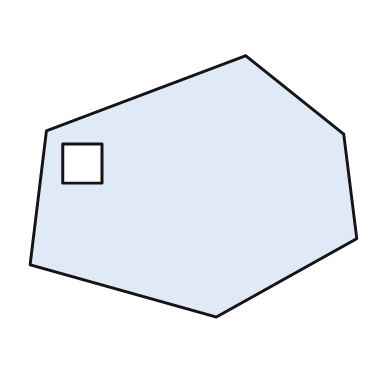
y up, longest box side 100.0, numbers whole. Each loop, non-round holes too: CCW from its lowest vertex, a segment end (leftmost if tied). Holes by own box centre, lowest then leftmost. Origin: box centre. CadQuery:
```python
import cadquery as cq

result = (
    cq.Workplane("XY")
    .moveTo(7.0, -40.0)
    .lineTo(50.0, -16.0)
    .lineTo(46.0, 16.0)
    .lineTo(16.0, 40.0)
    .lineTo(-45.0, 17.0)
    .lineTo(-50.0, -24.0)
    .close()
    .moveTo(-40.0, 1.0)
    .lineTo(-28.0, 1.0)
    .lineTo(-28.0, 13.0)
    .lineTo(-40.0, 13.0)
    .close()
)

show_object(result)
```